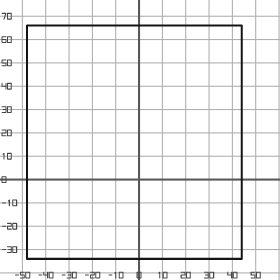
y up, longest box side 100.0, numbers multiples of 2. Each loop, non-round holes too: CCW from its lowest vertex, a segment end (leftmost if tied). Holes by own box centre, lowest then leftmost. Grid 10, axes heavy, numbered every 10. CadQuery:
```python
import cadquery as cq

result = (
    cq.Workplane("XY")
    .moveTo(-48.0, -34.0)
    .lineTo(44.0, -34.0)
    .lineTo(44.0, 66.0)
    .lineTo(-48.0, 66.0)
    .close()
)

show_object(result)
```